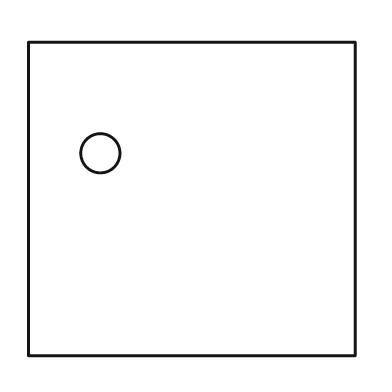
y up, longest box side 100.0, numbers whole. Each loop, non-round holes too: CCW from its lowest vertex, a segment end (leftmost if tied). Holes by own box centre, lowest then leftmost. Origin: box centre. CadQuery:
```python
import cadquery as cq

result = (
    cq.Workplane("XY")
    .moveTo(-50.0, -48.0)
    .lineTo(50.0, -48.0)
    .lineTo(50.0, 48.0)
    .lineTo(-50.0, 48.0)
    .close()
    .moveTo(-28.0, 14.0)
    .circle(6.0)
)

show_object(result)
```